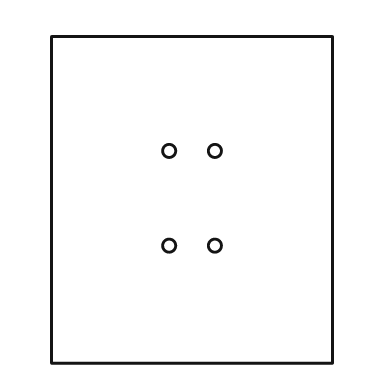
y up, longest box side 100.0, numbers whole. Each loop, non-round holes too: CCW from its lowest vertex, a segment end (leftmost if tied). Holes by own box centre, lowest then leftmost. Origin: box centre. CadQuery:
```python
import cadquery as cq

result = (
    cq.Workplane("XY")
    .moveTo(-43.0, -50.0)
    .lineTo(43.0, -50.0)
    .lineTo(43.0, 50.0)
    .lineTo(-43.0, 50.0)
    .close()
    .moveTo(-7.0, -14.0)
    .circle(2.0)
    .moveTo(7.0, -14.0)
    .circle(2.0)
    .moveTo(-7.0, 15.0)
    .circle(2.0)
    .moveTo(7.0, 15.0)
    .circle(2.0)
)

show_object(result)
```